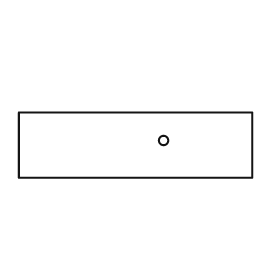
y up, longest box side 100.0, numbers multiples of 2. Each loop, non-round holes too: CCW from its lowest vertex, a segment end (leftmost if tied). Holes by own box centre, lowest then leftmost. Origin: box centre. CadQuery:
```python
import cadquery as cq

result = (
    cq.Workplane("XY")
    .moveTo(-50.0, -14.0)
    .lineTo(50.0, -14.0)
    .lineTo(50.0, 14.0)
    .lineTo(-50.0, 14.0)
    .close()
    .moveTo(12.0, 2.0)
    .circle(2.0)
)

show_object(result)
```